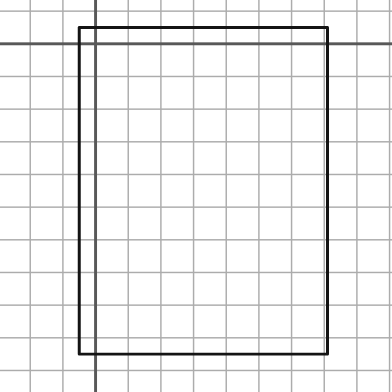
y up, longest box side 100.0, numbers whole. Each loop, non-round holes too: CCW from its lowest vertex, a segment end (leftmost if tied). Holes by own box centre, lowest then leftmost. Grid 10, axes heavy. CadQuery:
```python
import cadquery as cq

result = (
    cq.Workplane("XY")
    .moveTo(-5.0, -95.0)
    .lineTo(71.0, -95.0)
    .lineTo(71.0, 5.0)
    .lineTo(-5.0, 5.0)
    .close()
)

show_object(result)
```